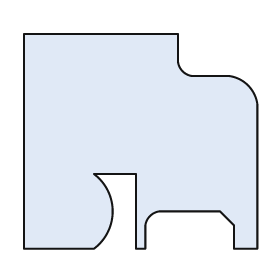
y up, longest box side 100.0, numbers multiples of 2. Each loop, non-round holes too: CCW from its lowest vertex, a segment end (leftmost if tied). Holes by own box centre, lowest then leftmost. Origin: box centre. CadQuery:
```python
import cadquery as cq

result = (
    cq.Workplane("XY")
    .moveTo(-50.0, -46.0)
    .lineTo(-20.0, -46.0)
    .threePointArc((-12.0, -30.0), (-20.0, -14.0))
    .lineTo(-2.0, -14.0)
    .lineTo(-2.0, -46.0)
    .lineTo(2.0, -46.0)
    .lineTo(2.0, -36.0)
    .threePointArc((4.0, -32.0), (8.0, -30.0))
    .lineTo(34.0, -30.0)
    .lineTo(40.0, -36.0)
    .lineTo(40.0, -46.0)
    .lineTo(50.0, -46.0)
    .lineTo(50.0, 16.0)
    .threePointArc((46.0, 24.0), (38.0, 28.0))
    .lineTo(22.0, 28.0)
    .threePointArc((18.0, 30.0), (16.0, 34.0))
    .lineTo(16.0, 46.0)
    .lineTo(-50.0, 46.0)
    .close()
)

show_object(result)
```